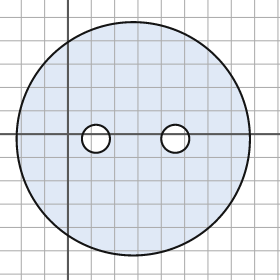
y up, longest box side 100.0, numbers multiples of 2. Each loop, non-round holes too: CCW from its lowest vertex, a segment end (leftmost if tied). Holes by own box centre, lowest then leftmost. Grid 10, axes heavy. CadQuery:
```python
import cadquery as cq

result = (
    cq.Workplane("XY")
    .moveTo(28.0, -2.0)
    .circle(50.0)
    .moveTo(12.0, -2.0)
    .circle(6.0)
    .moveTo(46.0, -2.0)
    .circle(6.0)
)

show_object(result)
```